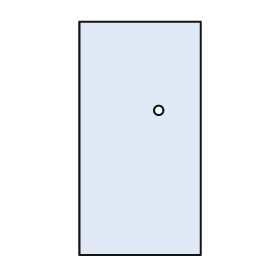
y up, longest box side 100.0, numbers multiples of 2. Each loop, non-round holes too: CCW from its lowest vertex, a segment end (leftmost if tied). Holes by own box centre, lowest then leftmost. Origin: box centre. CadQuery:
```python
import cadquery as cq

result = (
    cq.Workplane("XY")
    .moveTo(-26.0, -50.0)
    .lineTo(26.0, -50.0)
    .lineTo(26.0, 50.0)
    .lineTo(-26.0, 50.0)
    .close()
    .moveTo(8.0, 12.0)
    .circle(2.0)
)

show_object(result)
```